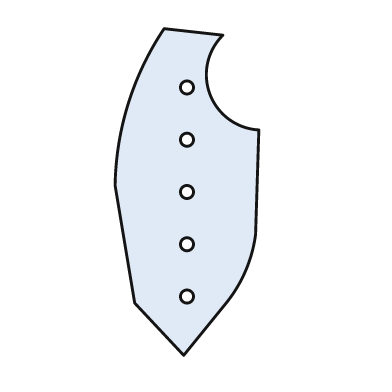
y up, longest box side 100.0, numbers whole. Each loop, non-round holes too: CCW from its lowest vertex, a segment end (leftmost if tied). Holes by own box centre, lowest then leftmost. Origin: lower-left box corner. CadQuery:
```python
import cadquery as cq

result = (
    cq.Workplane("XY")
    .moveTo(21.0, 0.0)
    .lineTo(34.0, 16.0)
    .threePointArc((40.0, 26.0), (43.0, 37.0))
    .lineTo(44.0, 69.0)
    .threePointArc((29.0, 80.0), (33.0, 98.0))
    .lineTo(15.0, 100.0)
    .threePointArc((4.0, 77.0), (0.0, 52.0))
    .lineTo(6.0, 16.0)
    .close()
    .moveTo(22.0, 18.0)
    .circle(2.0)
    .moveTo(22.0, 34.0)
    .circle(2.0)
    .moveTo(22.0, 50.0)
    .circle(2.0)
    .moveTo(22.0, 66.0)
    .circle(2.0)
    .moveTo(22.0, 82.0)
    .circle(2.0)
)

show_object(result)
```